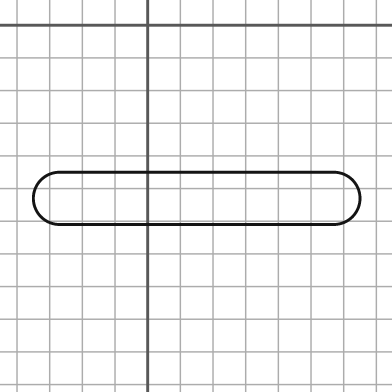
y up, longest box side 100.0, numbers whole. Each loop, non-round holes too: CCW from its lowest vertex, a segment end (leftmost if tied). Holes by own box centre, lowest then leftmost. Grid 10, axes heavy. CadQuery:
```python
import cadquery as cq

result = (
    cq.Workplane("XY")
    .moveTo(-27.0, -61.0)
    .lineTo(57.0, -61.0)
    .threePointArc((65.0, -53.0), (57.0, -45.0))
    .lineTo(-27.0, -45.0)
    .threePointArc((-35.0, -53.0), (-27.0, -61.0))
    .close()
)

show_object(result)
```